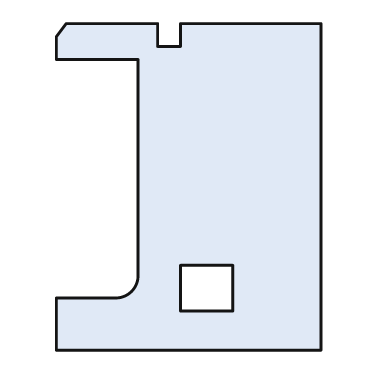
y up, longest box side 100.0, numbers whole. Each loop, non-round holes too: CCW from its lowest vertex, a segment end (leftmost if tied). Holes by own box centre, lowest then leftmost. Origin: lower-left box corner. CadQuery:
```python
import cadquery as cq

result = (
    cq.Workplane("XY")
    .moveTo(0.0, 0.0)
    .lineTo(81.0, 0.0)
    .lineTo(81.0, 100.0)
    .lineTo(38.0, 100.0)
    .lineTo(38.0, 93.0)
    .lineTo(31.0, 93.0)
    .lineTo(31.0, 100.0)
    .lineTo(3.0, 100.0)
    .lineTo(0.0, 96.0)
    .lineTo(0.0, 89.0)
    .lineTo(25.0, 89.0)
    .lineTo(25.0, 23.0)
    .threePointArc((23.0, 18.0), (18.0, 16.0))
    .lineTo(0.0, 16.0)
    .close()
    .moveTo(38.0, 12.0)
    .lineTo(54.0, 12.0)
    .lineTo(54.0, 26.0)
    .lineTo(38.0, 26.0)
    .close()
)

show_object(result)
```